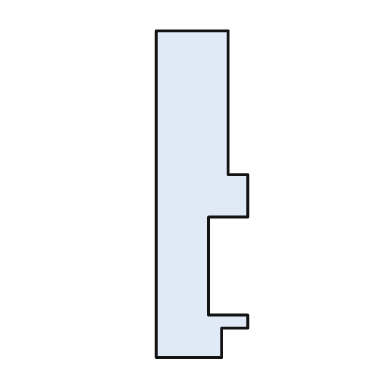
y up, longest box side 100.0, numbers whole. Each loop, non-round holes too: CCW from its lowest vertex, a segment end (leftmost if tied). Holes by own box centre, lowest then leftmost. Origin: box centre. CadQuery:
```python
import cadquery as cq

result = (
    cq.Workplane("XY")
    .moveTo(-14.0, -50.0)
    .lineTo(6.0, -50.0)
    .lineTo(6.0, -41.0)
    .lineTo(14.0, -41.0)
    .lineTo(14.0, -37.0)
    .lineTo(2.0, -37.0)
    .lineTo(2.0, -7.0)
    .lineTo(14.0, -7.0)
    .lineTo(14.0, 6.0)
    .lineTo(8.0, 6.0)
    .lineTo(8.0, 50.0)
    .lineTo(-14.0, 50.0)
    .close()
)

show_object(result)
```